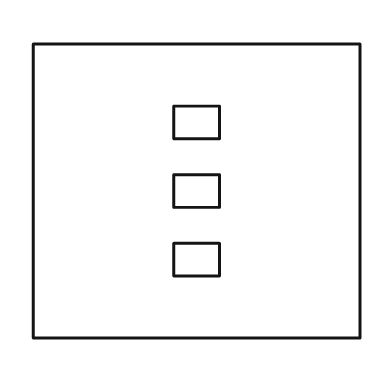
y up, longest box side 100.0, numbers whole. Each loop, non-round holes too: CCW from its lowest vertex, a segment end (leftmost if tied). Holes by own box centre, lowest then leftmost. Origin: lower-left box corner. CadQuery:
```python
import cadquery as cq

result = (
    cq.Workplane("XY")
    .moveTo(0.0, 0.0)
    .lineTo(100.0, 0.0)
    .lineTo(100.0, 90.0)
    .lineTo(0.0, 90.0)
    .close()
    .moveTo(43.0, 19.0)
    .lineTo(57.0, 19.0)
    .lineTo(57.0, 29.0)
    .lineTo(43.0, 29.0)
    .close()
    .moveTo(43.0, 40.0)
    .lineTo(57.0, 40.0)
    .lineTo(57.0, 50.0)
    .lineTo(43.0, 50.0)
    .close()
    .moveTo(43.0, 61.0)
    .lineTo(57.0, 61.0)
    .lineTo(57.0, 71.0)
    .lineTo(43.0, 71.0)
    .close()
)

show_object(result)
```